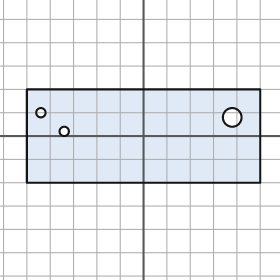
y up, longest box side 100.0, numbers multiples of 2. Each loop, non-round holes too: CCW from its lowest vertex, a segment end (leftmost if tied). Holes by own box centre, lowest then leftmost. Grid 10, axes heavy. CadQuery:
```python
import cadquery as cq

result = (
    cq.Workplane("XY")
    .moveTo(-50.0, -20.0)
    .lineTo(50.0, -20.0)
    .lineTo(50.0, 20.0)
    .lineTo(-50.0, 20.0)
    .close()
    .moveTo(-34.0, 2.0)
    .circle(2.0)
    .moveTo(38.0, 8.0)
    .circle(4.0)
    .moveTo(-44.0, 10.0)
    .circle(2.0)
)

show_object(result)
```